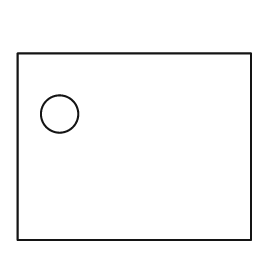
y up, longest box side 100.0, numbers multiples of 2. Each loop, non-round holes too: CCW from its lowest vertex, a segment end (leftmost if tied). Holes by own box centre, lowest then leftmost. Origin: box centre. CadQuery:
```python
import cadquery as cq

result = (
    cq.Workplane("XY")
    .moveTo(-50.0, -40.0)
    .lineTo(50.0, -40.0)
    .lineTo(50.0, 40.0)
    .lineTo(-50.0, 40.0)
    .close()
    .moveTo(-32.0, 14.0)
    .circle(8.0)
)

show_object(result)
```